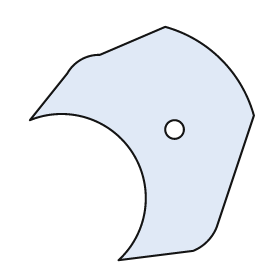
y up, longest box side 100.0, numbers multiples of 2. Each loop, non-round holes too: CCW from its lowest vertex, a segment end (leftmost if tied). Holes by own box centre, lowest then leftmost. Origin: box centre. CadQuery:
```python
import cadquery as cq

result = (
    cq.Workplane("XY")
    .moveTo(-10.0, -50.0)
    .lineTo(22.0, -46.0)
    .threePointArc((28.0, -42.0), (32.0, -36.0))
    .lineTo(48.0, 12.0)
    .threePointArc((34.0, 36.0), (10.0, 50.0))
    .lineTo(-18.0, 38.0)
    .threePointArc((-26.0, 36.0), (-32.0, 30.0))
    .lineTo(-48.0, 10.0)
    .threePointArc((-4.0, -4.0), (-10.0, -50.0))
    .close()
    .moveTo(14.0, 6.0)
    .circle(4.0)
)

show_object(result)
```